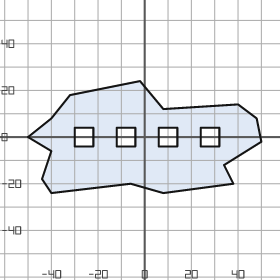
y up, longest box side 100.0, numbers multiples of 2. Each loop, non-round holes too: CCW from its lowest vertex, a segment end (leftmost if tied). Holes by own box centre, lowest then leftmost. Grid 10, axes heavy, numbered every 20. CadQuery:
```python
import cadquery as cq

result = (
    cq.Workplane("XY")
    .moveTo(-40.0, -24.0)
    .lineTo(-6.0, -20.0)
    .lineTo(8.0, -24.0)
    .lineTo(38.0, -20.0)
    .lineTo(34.0, -12.0)
    .lineTo(50.0, -2.0)
    .lineTo(48.0, 8.0)
    .lineTo(40.0, 14.0)
    .lineTo(8.0, 12.0)
    .lineTo(-2.0, 24.0)
    .lineTo(-32.0, 18.0)
    .lineTo(-40.0, 8.0)
    .lineTo(-50.0, 0.0)
    .lineTo(-40.0, -6.0)
    .lineTo(-44.0, -18.0)
    .close()
    .moveTo(-30.0, -4.0)
    .lineTo(-22.0, -4.0)
    .lineTo(-22.0, 4.0)
    .lineTo(-30.0, 4.0)
    .close()
    .moveTo(-12.0, -4.0)
    .lineTo(-4.0, -4.0)
    .lineTo(-4.0, 4.0)
    .lineTo(-12.0, 4.0)
    .close()
    .moveTo(6.0, -4.0)
    .lineTo(14.0, -4.0)
    .lineTo(14.0, 4.0)
    .lineTo(6.0, 4.0)
    .close()
    .moveTo(24.0, -4.0)
    .lineTo(32.0, -4.0)
    .lineTo(32.0, 4.0)
    .lineTo(24.0, 4.0)
    .close()
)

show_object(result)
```